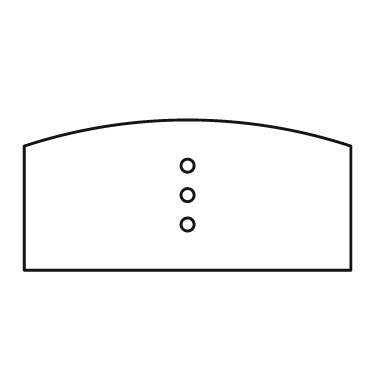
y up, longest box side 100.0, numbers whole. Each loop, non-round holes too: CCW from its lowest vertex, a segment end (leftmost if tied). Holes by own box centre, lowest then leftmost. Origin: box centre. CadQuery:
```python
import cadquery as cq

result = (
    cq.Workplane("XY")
    .moveTo(-50.0, -23.0)
    .lineTo(50.0, -23.0)
    .lineTo(50.0, 15.0)
    .threePointArc((0.0, 23.0), (-50.0, 15.0))
    .close()
    .moveTo(0.0, -9.0)
    .circle(2.0)
    .moveTo(0.0, 0.0)
    .circle(2.0)
    .moveTo(0.0, 9.0)
    .circle(2.0)
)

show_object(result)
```